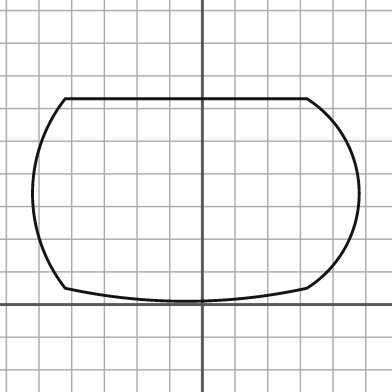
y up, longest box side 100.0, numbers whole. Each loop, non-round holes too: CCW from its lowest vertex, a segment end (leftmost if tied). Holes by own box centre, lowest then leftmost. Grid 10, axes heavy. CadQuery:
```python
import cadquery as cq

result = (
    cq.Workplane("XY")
    .moveTo(-42.0, 5.0)
    .threePointArc((-5.0, 1.0), (32.0, 5.0))
    .threePointArc((48.0, 34.0), (32.0, 63.0))
    .lineTo(-42.0, 63.0)
    .threePointArc((-52.0, 34.0), (-42.0, 5.0))
    .close()
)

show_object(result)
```